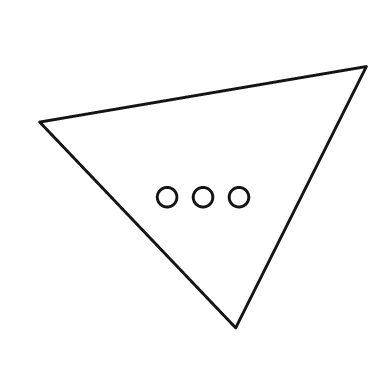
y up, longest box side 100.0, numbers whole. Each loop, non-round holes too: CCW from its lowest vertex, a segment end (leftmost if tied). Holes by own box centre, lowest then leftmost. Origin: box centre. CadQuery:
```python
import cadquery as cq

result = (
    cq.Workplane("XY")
    .moveTo(10.0, -40.0)
    .lineTo(50.0, 40.0)
    .lineTo(-50.0, 23.0)
    .close()
    .moveTo(-11.0, 0.0)
    .circle(3.0)
    .moveTo(0.0, 0.0)
    .circle(3.0)
    .moveTo(11.0, 0.0)
    .circle(3.0)
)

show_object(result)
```